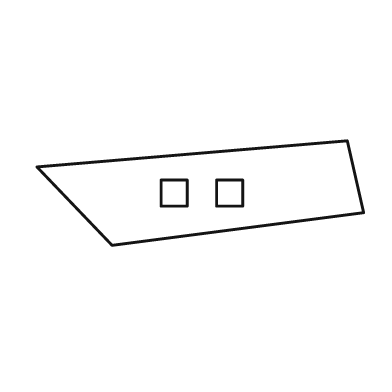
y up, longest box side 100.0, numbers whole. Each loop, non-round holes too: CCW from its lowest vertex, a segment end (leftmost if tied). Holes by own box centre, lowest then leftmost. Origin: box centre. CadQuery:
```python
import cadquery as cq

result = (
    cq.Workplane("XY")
    .moveTo(-27.0, -16.0)
    .lineTo(50.0, -6.0)
    .lineTo(45.0, 16.0)
    .lineTo(-50.0, 8.0)
    .close()
    .moveTo(-12.0, -4.0)
    .lineTo(-4.0, -4.0)
    .lineTo(-4.0, 4.0)
    .lineTo(-12.0, 4.0)
    .close()
    .moveTo(5.0, -4.0)
    .lineTo(13.0, -4.0)
    .lineTo(13.0, 4.0)
    .lineTo(5.0, 4.0)
    .close()
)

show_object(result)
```